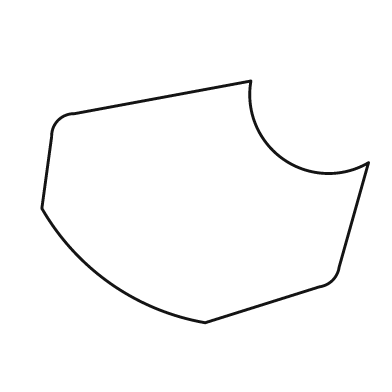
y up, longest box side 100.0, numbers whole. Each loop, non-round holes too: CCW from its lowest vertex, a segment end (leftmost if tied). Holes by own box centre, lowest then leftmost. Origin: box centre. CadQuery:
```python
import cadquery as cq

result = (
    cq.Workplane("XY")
    .moveTo(0.0, -37.0)
    .lineTo(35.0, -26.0)
    .threePointArc((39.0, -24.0), (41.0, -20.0))
    .lineTo(50.0, 12.0)
    .threePointArc((24.0, 13.0), (14.0, 37.0))
    .lineTo(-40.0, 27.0)
    .threePointArc((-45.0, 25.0), (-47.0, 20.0))
    .lineTo(-50.0, -2.0)
    .threePointArc((-29.0, -25.0), (0.0, -37.0))
    .close()
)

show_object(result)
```